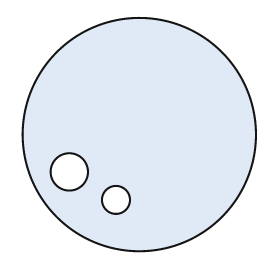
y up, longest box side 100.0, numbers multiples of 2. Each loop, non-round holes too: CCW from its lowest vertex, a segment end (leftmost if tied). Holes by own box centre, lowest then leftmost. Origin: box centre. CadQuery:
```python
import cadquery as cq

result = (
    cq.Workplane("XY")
    .moveTo(0.0, 0.0)
    .circle(50.0)
    .moveTo(-10.0, -28.0)
    .circle(6.0)
    .moveTo(-30.0, -16.0)
    .circle(8.0)
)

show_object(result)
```